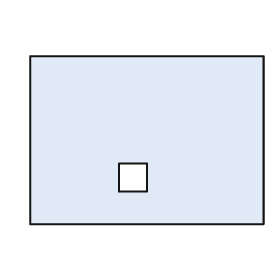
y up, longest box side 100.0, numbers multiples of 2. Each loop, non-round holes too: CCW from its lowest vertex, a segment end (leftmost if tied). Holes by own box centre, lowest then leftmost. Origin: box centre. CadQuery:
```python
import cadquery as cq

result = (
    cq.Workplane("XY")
    .moveTo(-50.0, -36.0)
    .lineTo(50.0, -36.0)
    .lineTo(50.0, 36.0)
    .lineTo(-50.0, 36.0)
    .close()
    .moveTo(-12.0, -22.0)
    .lineTo(0.0, -22.0)
    .lineTo(0.0, -10.0)
    .lineTo(-12.0, -10.0)
    .close()
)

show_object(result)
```